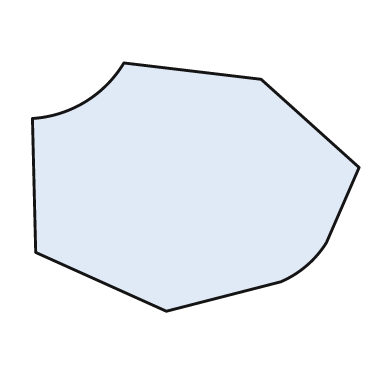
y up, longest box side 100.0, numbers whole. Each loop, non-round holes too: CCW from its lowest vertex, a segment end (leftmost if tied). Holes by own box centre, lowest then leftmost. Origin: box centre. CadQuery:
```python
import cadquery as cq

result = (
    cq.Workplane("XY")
    .moveTo(-9.0, -38.0)
    .lineTo(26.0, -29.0)
    .threePointArc((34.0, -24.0), (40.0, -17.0))
    .lineTo(50.0, 6.0)
    .lineTo(20.0, 33.0)
    .lineTo(-22.0, 38.0)
    .threePointArc((-34.0, 26.0), (-50.0, 21.0))
    .lineTo(-49.0, -20.0)
    .close()
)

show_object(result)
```